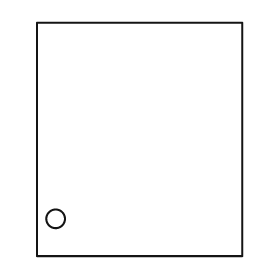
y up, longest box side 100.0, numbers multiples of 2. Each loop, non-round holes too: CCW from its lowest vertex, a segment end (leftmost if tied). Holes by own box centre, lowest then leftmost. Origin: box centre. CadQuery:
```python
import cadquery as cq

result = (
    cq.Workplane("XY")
    .moveTo(-44.0, -50.0)
    .lineTo(44.0, -50.0)
    .lineTo(44.0, 50.0)
    .lineTo(-44.0, 50.0)
    .close()
    .moveTo(-36.0, -34.0)
    .circle(4.0)
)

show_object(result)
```